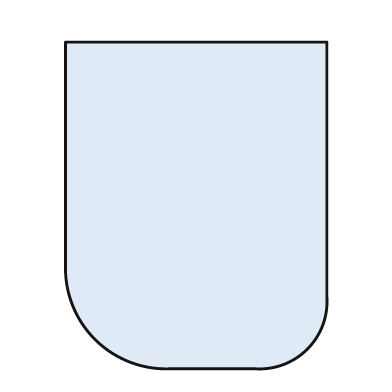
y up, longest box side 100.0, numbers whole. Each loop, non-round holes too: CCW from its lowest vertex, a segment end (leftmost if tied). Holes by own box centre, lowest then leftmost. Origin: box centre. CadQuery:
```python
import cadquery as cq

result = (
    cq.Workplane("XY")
    .moveTo(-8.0, -50.0)
    .lineTo(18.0, -50.0)
    .threePointArc((34.0, -44.0), (40.0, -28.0))
    .lineTo(40.0, 50.0)
    .lineTo(-40.0, 50.0)
    .lineTo(-40.0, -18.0)
    .threePointArc((-31.0, -41.0), (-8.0, -50.0))
    .close()
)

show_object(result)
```